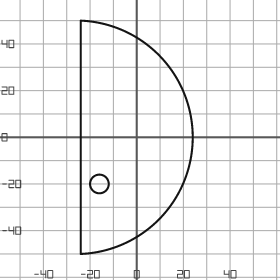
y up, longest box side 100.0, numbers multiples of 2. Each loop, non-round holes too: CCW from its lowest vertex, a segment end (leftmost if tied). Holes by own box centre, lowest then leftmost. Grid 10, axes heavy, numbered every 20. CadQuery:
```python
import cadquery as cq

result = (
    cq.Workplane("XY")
    .moveTo(-24.0, -50.0)
    .threePointArc((24.0, 0.0), (-24.0, 50.0))
    .close()
    .moveTo(-16.0, -20.0)
    .circle(4.0)
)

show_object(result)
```